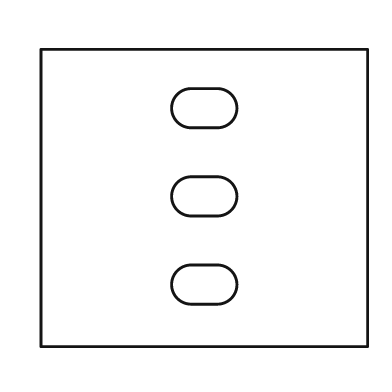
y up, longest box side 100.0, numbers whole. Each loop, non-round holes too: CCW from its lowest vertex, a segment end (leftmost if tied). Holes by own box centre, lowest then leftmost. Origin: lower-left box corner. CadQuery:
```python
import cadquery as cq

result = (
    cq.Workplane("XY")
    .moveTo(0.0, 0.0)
    .lineTo(100.0, 0.0)
    .lineTo(100.0, 91.0)
    .lineTo(0.0, 91.0)
    .close()
    .moveTo(46.0, 13.0)
    .lineTo(54.0, 13.0)
    .threePointArc((60.0, 19.0), (54.0, 25.0))
    .lineTo(46.0, 25.0)
    .threePointArc((40.0, 19.0), (46.0, 13.0))
    .close()
    .moveTo(46.0, 40.0)
    .lineTo(54.0, 40.0)
    .threePointArc((60.0, 46.0), (54.0, 52.0))
    .lineTo(46.0, 52.0)
    .threePointArc((40.0, 46.0), (46.0, 40.0))
    .close()
    .moveTo(46.0, 67.0)
    .lineTo(54.0, 67.0)
    .threePointArc((60.0, 73.0), (54.0, 79.0))
    .lineTo(46.0, 79.0)
    .threePointArc((40.0, 73.0), (46.0, 67.0))
    .close()
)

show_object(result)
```